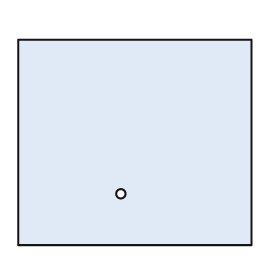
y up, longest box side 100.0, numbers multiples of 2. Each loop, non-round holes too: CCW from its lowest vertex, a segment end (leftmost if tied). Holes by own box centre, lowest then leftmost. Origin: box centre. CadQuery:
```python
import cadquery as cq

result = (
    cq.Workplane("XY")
    .moveTo(-50.0, -44.0)
    .lineTo(50.0, -44.0)
    .lineTo(50.0, 44.0)
    .lineTo(-50.0, 44.0)
    .close()
    .moveTo(-6.0, -22.0)
    .circle(2.0)
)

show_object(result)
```